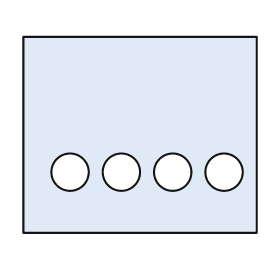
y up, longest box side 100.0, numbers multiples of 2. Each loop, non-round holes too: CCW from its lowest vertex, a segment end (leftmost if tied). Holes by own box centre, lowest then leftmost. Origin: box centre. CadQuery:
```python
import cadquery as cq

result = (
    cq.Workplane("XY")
    .moveTo(-50.0, -42.0)
    .lineTo(50.0, -42.0)
    .lineTo(50.0, 42.0)
    .lineTo(-50.0, 42.0)
    .close()
    .moveTo(-30.0, -16.0)
    .circle(8.0)
    .moveTo(-8.0, -16.0)
    .circle(8.0)
    .moveTo(14.0, -16.0)
    .circle(8.0)
    .moveTo(36.0, -16.0)
    .circle(8.0)
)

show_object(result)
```